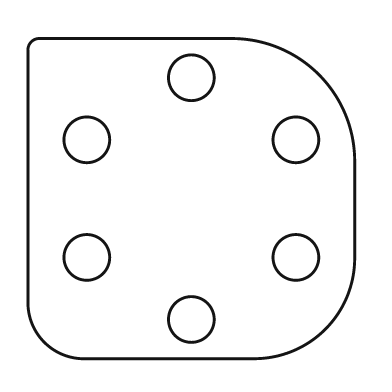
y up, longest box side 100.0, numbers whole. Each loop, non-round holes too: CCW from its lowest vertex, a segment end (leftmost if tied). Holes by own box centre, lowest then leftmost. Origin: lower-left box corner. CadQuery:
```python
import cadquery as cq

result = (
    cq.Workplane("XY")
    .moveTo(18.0, 0.0)
    .lineTo(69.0, 0.0)
    .threePointArc((91.0, 9.0), (100.0, 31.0))
    .lineTo(100.0, 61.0)
    .threePointArc((89.0, 87.0), (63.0, 98.0))
    .lineTo(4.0, 98.0)
    .threePointArc((1.0, 97.0), (0.0, 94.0))
    .lineTo(0.0, 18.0)
    .threePointArc((5.0, 5.0), (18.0, 0.0))
    .close()
    .moveTo(50.0, 12.0)
    .circle(7.0)
    .moveTo(18.0, 31.0)
    .circle(7.0)
    .moveTo(82.0, 31.0)
    .circle(7.0)
    .moveTo(18.0, 67.0)
    .circle(7.0)
    .moveTo(82.0, 67.0)
    .circle(7.0)
    .moveTo(50.0, 86.0)
    .circle(7.0)
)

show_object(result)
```